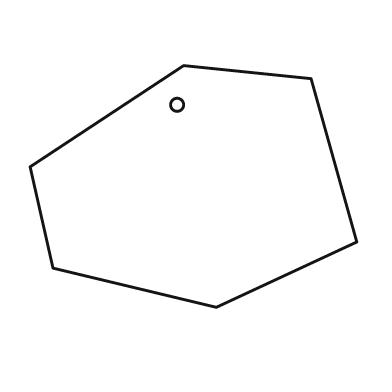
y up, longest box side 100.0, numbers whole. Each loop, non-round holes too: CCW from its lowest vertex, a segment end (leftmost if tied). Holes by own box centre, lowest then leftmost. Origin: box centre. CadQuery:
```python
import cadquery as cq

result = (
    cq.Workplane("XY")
    .moveTo(7.0, -37.0)
    .lineTo(50.0, -17.0)
    .lineTo(36.0, 33.0)
    .lineTo(-3.0, 37.0)
    .lineTo(-50.0, 6.0)
    .lineTo(-43.0, -25.0)
    .close()
    .moveTo(-5.0, 25.0)
    .circle(2.0)
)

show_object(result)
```